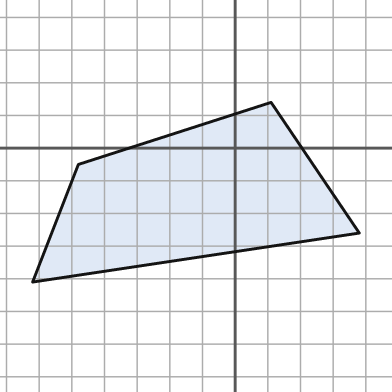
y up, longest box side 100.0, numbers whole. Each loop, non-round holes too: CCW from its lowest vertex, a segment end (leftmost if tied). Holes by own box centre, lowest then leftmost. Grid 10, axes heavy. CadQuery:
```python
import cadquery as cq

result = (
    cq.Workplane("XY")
    .moveTo(-62.0, -41.0)
    .lineTo(38.0, -26.0)
    .lineTo(11.0, 14.0)
    .lineTo(-48.0, -5.0)
    .close()
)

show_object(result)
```